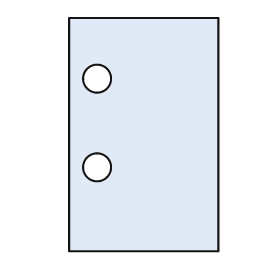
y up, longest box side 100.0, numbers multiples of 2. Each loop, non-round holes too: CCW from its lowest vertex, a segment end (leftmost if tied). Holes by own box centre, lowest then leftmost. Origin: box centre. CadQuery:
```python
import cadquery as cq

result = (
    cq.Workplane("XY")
    .moveTo(-32.0, -50.0)
    .lineTo(32.0, -50.0)
    .lineTo(32.0, 50.0)
    .lineTo(-32.0, 50.0)
    .close()
    .moveTo(-20.0, -14.0)
    .circle(6.0)
    .moveTo(-20.0, 24.0)
    .circle(6.0)
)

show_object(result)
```